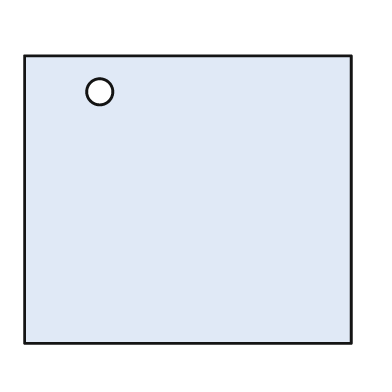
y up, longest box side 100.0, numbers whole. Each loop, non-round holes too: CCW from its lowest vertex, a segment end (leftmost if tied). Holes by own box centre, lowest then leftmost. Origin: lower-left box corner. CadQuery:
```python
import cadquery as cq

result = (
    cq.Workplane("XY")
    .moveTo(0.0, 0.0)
    .lineTo(100.0, 0.0)
    .lineTo(100.0, 88.0)
    .lineTo(0.0, 88.0)
    .close()
    .moveTo(23.0, 77.0)
    .circle(4.0)
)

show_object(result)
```